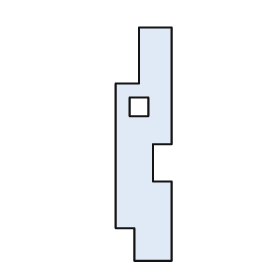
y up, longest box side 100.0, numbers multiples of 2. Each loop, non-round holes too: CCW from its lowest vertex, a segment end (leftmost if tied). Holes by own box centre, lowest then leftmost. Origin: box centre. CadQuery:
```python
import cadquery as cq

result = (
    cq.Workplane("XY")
    .moveTo(-4.0, -50.0)
    .lineTo(12.0, -50.0)
    .lineTo(12.0, -16.0)
    .lineTo(4.0, -16.0)
    .lineTo(4.0, 0.0)
    .lineTo(12.0, 0.0)
    .lineTo(12.0, 50.0)
    .lineTo(-2.0, 50.0)
    .lineTo(-2.0, 26.0)
    .lineTo(-12.0, 26.0)
    .lineTo(-12.0, -36.0)
    .lineTo(-4.0, -36.0)
    .close()
    .moveTo(-6.0, 12.0)
    .lineTo(2.0, 12.0)
    .lineTo(2.0, 20.0)
    .lineTo(-6.0, 20.0)
    .close()
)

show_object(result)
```